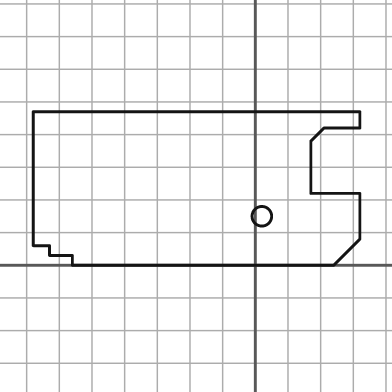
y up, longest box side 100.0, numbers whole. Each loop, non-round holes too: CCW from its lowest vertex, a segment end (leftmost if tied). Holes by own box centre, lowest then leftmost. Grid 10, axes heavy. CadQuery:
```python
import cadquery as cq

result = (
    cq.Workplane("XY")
    .moveTo(-56.0, 0.0)
    .lineTo(24.0, 0.0)
    .lineTo(32.0, 8.0)
    .lineTo(32.0, 22.0)
    .lineTo(17.0, 22.0)
    .lineTo(17.0, 38.0)
    .lineTo(21.0, 42.0)
    .lineTo(32.0, 42.0)
    .lineTo(32.0, 47.0)
    .lineTo(-68.0, 47.0)
    .lineTo(-68.0, 6.0)
    .lineTo(-63.0, 6.0)
    .lineTo(-63.0, 3.0)
    .lineTo(-56.0, 3.0)
    .close()
    .moveTo(2.0, 15.0)
    .circle(3.0)
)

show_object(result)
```